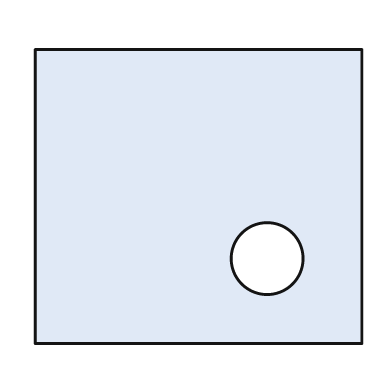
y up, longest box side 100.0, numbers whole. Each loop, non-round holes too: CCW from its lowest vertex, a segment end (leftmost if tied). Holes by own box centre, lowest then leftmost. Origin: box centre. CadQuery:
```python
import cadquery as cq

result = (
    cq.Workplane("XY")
    .moveTo(-50.0, -45.0)
    .lineTo(50.0, -45.0)
    .lineTo(50.0, 45.0)
    .lineTo(-50.0, 45.0)
    .close()
    .moveTo(21.0, -19.0)
    .circle(11.0)
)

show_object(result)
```